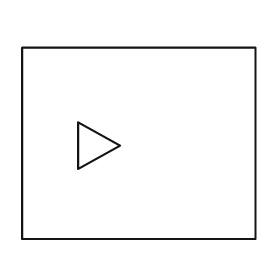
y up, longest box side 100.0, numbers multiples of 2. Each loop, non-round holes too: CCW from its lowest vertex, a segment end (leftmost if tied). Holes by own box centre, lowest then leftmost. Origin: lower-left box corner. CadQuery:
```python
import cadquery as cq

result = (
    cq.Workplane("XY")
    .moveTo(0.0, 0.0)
    .lineTo(100.0, 0.0)
    .lineTo(100.0, 82.0)
    .lineTo(0.0, 82.0)
    .close()
    .moveTo(24.0, 30.0)
    .lineTo(42.0, 40.0)
    .lineTo(24.0, 50.0)
    .close()
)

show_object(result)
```